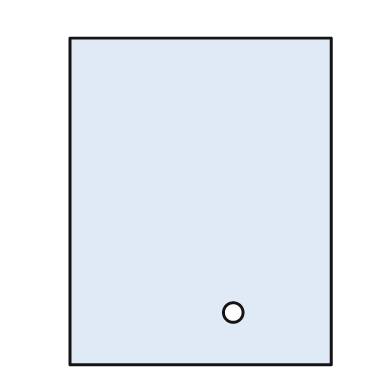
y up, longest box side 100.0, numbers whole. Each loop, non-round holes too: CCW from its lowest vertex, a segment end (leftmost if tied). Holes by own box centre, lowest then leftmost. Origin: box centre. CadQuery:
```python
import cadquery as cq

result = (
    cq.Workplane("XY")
    .moveTo(-40.0, -50.0)
    .lineTo(40.0, -50.0)
    .lineTo(40.0, 50.0)
    .lineTo(-40.0, 50.0)
    .close()
    .moveTo(10.0, -34.0)
    .circle(3.0)
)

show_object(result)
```